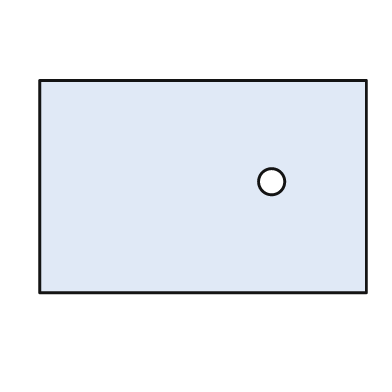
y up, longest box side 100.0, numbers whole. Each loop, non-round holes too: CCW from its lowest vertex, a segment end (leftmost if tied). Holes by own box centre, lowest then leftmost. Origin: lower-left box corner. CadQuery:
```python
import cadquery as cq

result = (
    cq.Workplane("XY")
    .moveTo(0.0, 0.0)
    .lineTo(100.0, 0.0)
    .lineTo(100.0, 65.0)
    .lineTo(0.0, 65.0)
    .close()
    .moveTo(71.0, 34.0)
    .circle(4.0)
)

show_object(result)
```